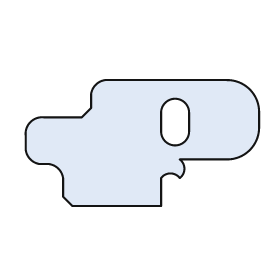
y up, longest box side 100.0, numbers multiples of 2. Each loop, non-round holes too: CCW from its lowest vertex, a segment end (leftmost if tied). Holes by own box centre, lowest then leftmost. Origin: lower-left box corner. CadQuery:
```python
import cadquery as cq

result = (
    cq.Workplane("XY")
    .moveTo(20.0, 0.0)
    .lineTo(58.0, 0.0)
    .lineTo(58.0, 12.0)
    .threePointArc((62.0, 14.0), (66.0, 12.0))
    .threePointArc((68.0, 16.0), (66.0, 20.0))
    .lineTo(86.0, 20.0)
    .threePointArc((96.0, 24.0), (100.0, 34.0))
    .lineTo(100.0, 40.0)
    .threePointArc((96.0, 50.0), (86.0, 54.0))
    .lineTo(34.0, 54.0)
    .threePointArc((30.0, 52.0), (28.0, 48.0))
    .lineTo(28.0, 42.0)
    .lineTo(24.0, 38.0)
    .lineTo(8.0, 38.0)
    .threePointArc((2.0, 36.0), (0.0, 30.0))
    .lineTo(0.0, 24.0)
    .threePointArc((2.0, 20.0), (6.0, 18.0))
    .lineTo(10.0, 18.0)
    .threePointArc((14.0, 16.0), (16.0, 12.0))
    .lineTo(16.0, 4.0)
    .close()
    .moveTo(58.0, 32.0)
    .threePointArc((64.0, 26.0), (70.0, 32.0))
    .lineTo(70.0, 40.0)
    .threePointArc((64.0, 46.0), (58.0, 40.0))
    .close()
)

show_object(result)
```